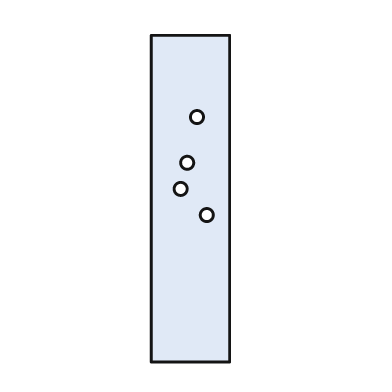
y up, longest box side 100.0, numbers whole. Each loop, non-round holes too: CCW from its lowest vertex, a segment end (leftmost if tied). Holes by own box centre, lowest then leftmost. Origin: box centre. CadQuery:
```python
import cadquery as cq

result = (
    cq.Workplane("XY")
    .moveTo(-12.0, -50.0)
    .lineTo(12.0, -50.0)
    .lineTo(12.0, 50.0)
    .lineTo(-12.0, 50.0)
    .close()
    .moveTo(5.0, -5.0)
    .circle(2.0)
    .moveTo(-3.0, 3.0)
    .circle(2.0)
    .moveTo(-1.0, 11.0)
    .circle(2.0)
    .moveTo(2.0, 25.0)
    .circle(2.0)
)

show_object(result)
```